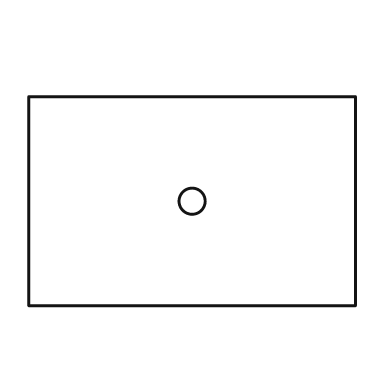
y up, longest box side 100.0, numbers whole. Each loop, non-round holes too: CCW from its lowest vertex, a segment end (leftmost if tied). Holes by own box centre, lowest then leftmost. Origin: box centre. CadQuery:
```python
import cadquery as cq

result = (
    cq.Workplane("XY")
    .moveTo(-50.0, -32.0)
    .lineTo(50.0, -32.0)
    .lineTo(50.0, 32.0)
    .lineTo(-50.0, 32.0)
    .close()
    .moveTo(0.0, 0.0)
    .circle(4.0)
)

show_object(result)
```